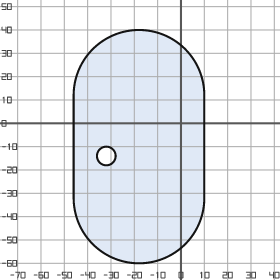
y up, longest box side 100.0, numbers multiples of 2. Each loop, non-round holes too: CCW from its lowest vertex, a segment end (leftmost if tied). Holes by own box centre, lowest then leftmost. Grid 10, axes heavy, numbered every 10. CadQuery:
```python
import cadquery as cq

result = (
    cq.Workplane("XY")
    .moveTo(-46.0, -32.0)
    .threePointArc((-18.0, -60.0), (10.0, -32.0))
    .lineTo(10.0, 12.0)
    .threePointArc((-18.0, 40.0), (-46.0, 12.0))
    .close()
    .moveTo(-32.0, -14.0)
    .circle(4.0)
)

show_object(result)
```